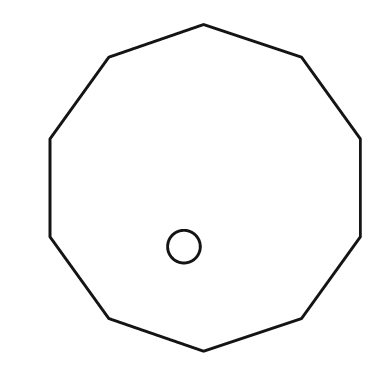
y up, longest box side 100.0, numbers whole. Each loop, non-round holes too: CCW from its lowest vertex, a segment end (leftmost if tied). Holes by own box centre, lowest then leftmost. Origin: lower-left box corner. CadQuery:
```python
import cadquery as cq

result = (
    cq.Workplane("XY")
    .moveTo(47.0, 0.0)
    .lineTo(77.0, 10.0)
    .lineTo(95.0, 35.0)
    .lineTo(95.0, 65.0)
    .lineTo(77.0, 90.0)
    .lineTo(47.0, 100.0)
    .lineTo(18.0, 90.0)
    .lineTo(0.0, 65.0)
    .lineTo(0.0, 35.0)
    .lineTo(18.0, 10.0)
    .close()
    .moveTo(41.0, 32.0)
    .circle(5.0)
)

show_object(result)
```